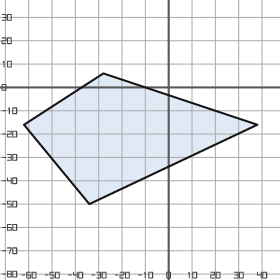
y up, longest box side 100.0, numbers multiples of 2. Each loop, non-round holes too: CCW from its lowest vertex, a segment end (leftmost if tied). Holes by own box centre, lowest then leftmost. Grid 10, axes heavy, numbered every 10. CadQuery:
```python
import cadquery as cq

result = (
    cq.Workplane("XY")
    .moveTo(-34.0, -50.0)
    .lineTo(38.0, -16.0)
    .lineTo(-28.0, 6.0)
    .lineTo(-62.0, -16.0)
    .close()
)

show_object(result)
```